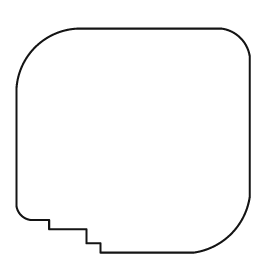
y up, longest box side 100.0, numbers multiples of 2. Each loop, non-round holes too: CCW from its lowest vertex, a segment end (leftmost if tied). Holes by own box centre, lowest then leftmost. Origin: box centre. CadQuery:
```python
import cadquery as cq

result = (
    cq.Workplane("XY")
    .moveTo(-14.0, -48.0)
    .lineTo(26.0, -48.0)
    .threePointArc((42.0, -40.0), (50.0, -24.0))
    .lineTo(50.0, 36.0)
    .threePointArc((46.0, 44.0), (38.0, 48.0))
    .lineTo(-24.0, 48.0)
    .threePointArc((-42.0, 40.0), (-50.0, 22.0))
    .lineTo(-50.0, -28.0)
    .threePointArc((-48.0, -32.0), (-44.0, -34.0))
    .lineTo(-36.0, -34.0)
    .lineTo(-36.0, -38.0)
    .lineTo(-20.0, -38.0)
    .lineTo(-20.0, -44.0)
    .lineTo(-14.0, -44.0)
    .close()
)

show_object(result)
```